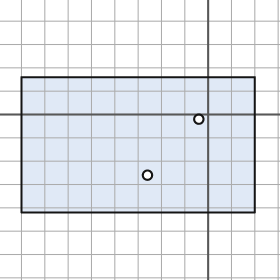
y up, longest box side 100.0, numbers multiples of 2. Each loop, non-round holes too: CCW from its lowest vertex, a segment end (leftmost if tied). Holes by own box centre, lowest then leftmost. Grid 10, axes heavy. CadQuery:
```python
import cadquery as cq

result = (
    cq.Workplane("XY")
    .moveTo(-80.0, -42.0)
    .lineTo(20.0, -42.0)
    .lineTo(20.0, 16.0)
    .lineTo(-80.0, 16.0)
    .close()
    .moveTo(-26.0, -26.0)
    .circle(2.0)
    .moveTo(-4.0, -2.0)
    .circle(2.0)
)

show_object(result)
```